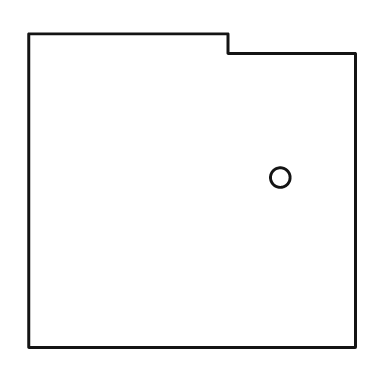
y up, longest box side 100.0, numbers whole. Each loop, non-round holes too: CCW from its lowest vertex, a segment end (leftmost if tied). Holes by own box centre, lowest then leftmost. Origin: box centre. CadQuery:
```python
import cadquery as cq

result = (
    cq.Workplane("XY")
    .moveTo(-50.0, -48.0)
    .lineTo(50.0, -48.0)
    .lineTo(50.0, 42.0)
    .lineTo(11.0, 42.0)
    .lineTo(11.0, 48.0)
    .lineTo(-50.0, 48.0)
    .close()
    .moveTo(27.0, 4.0)
    .circle(3.0)
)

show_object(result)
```